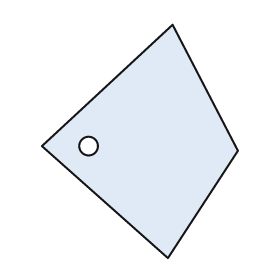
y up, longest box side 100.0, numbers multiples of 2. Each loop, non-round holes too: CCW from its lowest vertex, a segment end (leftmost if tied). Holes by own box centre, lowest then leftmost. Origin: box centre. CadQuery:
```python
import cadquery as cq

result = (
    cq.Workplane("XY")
    .moveTo(12.0, -50.0)
    .lineTo(42.0, -4.0)
    .lineTo(14.0, 50.0)
    .lineTo(-42.0, -2.0)
    .close()
    .moveTo(-22.0, -2.0)
    .circle(4.0)
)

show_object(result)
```